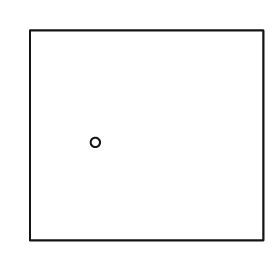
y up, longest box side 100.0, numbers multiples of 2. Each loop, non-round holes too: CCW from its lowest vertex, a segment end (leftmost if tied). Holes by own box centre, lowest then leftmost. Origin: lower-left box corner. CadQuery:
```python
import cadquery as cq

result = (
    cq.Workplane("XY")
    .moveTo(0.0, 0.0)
    .lineTo(100.0, 0.0)
    .lineTo(100.0, 90.0)
    .lineTo(0.0, 90.0)
    .close()
    .moveTo(28.0, 42.0)
    .circle(2.0)
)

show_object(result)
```